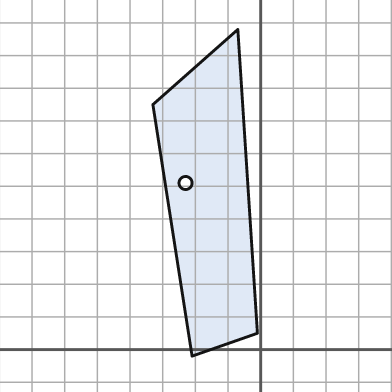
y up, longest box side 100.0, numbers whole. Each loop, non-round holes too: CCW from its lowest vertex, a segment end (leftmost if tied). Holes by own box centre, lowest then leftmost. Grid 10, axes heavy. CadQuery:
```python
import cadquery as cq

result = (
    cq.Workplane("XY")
    .moveTo(-21.0, -2.0)
    .lineTo(-1.0, 5.0)
    .lineTo(-7.0, 98.0)
    .lineTo(-33.0, 75.0)
    .close()
    .moveTo(-23.0, 51.0)
    .circle(2.0)
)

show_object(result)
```